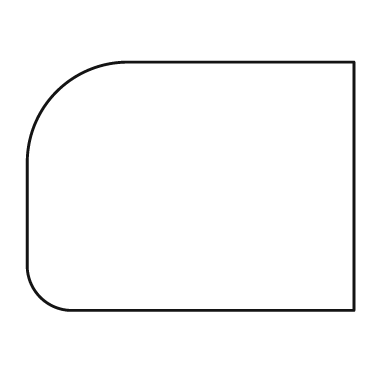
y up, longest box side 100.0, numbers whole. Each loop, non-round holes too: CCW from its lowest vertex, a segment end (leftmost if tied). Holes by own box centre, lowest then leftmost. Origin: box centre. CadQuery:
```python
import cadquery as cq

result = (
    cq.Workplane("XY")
    .moveTo(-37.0, -38.0)
    .lineTo(50.0, -38.0)
    .lineTo(50.0, 38.0)
    .lineTo(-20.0, 38.0)
    .threePointArc((-41.0, 29.0), (-50.0, 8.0))
    .lineTo(-50.0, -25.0)
    .threePointArc((-46.0, -34.0), (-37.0, -38.0))
    .close()
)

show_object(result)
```